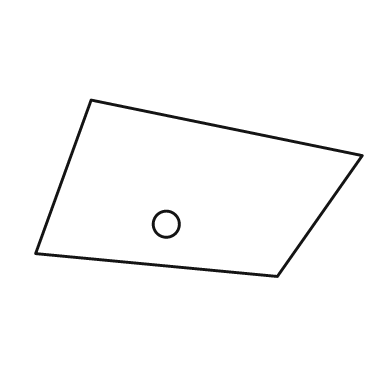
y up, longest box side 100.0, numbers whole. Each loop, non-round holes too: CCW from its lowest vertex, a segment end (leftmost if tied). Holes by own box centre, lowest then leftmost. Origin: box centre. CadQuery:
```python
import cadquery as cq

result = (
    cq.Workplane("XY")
    .moveTo(24.0, -27.0)
    .lineTo(50.0, 10.0)
    .lineTo(-33.0, 27.0)
    .lineTo(-50.0, -20.0)
    .close()
    .moveTo(-10.0, -11.0)
    .circle(4.0)
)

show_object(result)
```